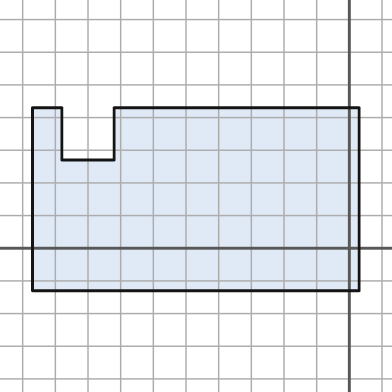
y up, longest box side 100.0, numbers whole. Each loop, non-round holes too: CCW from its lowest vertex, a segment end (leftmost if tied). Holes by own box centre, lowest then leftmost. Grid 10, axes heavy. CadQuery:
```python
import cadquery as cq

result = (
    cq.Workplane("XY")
    .moveTo(-97.0, -13.0)
    .lineTo(3.0, -13.0)
    .lineTo(3.0, 43.0)
    .lineTo(-72.0, 43.0)
    .lineTo(-72.0, 27.0)
    .lineTo(-88.0, 27.0)
    .lineTo(-88.0, 43.0)
    .lineTo(-97.0, 43.0)
    .close()
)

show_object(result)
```